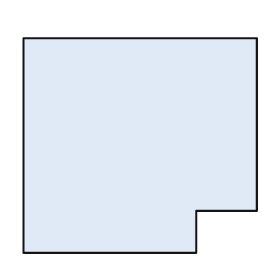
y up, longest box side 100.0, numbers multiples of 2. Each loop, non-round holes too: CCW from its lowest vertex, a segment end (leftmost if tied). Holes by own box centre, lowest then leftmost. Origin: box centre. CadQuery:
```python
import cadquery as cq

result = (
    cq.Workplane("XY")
    .moveTo(-50.0, -46.0)
    .lineTo(24.0, -46.0)
    .lineTo(24.0, -28.0)
    .lineTo(50.0, -28.0)
    .lineTo(50.0, 46.0)
    .lineTo(-50.0, 46.0)
    .close()
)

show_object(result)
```